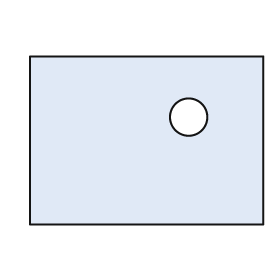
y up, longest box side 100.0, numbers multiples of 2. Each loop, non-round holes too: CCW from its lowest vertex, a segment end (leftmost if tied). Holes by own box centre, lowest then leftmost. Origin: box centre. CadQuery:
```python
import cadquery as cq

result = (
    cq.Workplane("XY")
    .moveTo(-50.0, -36.0)
    .lineTo(50.0, -36.0)
    .lineTo(50.0, 36.0)
    .lineTo(-50.0, 36.0)
    .close()
    .moveTo(18.0, 10.0)
    .circle(8.0)
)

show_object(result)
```